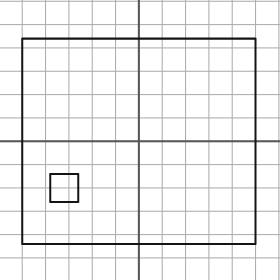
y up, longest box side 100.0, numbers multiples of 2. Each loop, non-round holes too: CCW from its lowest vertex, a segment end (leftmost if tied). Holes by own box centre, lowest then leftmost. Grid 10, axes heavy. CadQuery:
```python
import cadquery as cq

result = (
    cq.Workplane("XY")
    .moveTo(-50.0, -44.0)
    .lineTo(50.0, -44.0)
    .lineTo(50.0, 44.0)
    .lineTo(-50.0, 44.0)
    .close()
    .moveTo(-38.0, -26.0)
    .lineTo(-26.0, -26.0)
    .lineTo(-26.0, -14.0)
    .lineTo(-38.0, -14.0)
    .close()
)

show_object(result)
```